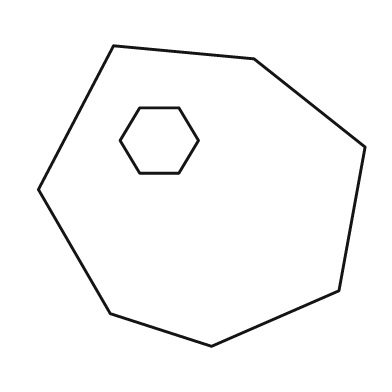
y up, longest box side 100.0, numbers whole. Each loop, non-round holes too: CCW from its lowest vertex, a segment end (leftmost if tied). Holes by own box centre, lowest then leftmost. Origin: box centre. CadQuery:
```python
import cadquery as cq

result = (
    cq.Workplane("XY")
    .moveTo(3.0, -46.0)
    .lineTo(42.0, -29.0)
    .lineTo(50.0, 15.0)
    .lineTo(16.0, 42.0)
    .lineTo(-27.0, 46.0)
    .lineTo(-50.0, 2.0)
    .lineTo(-28.0, -36.0)
    .close()
    .moveTo(-19.0, 7.0)
    .lineTo(-7.0, 7.0)
    .lineTo(-1.0, 17.0)
    .lineTo(-7.0, 27.0)
    .lineTo(-19.0, 27.0)
    .lineTo(-25.0, 17.0)
    .close()
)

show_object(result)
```